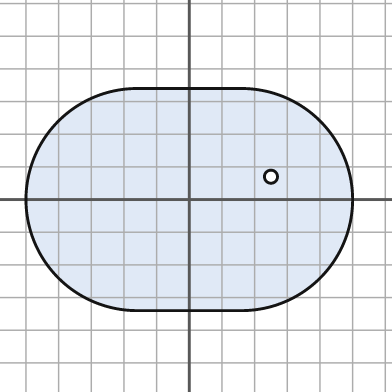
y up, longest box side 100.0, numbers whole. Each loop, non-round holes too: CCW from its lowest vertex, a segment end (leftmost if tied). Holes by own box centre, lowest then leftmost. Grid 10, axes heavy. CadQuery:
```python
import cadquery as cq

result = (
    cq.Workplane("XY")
    .moveTo(-16.0, -34.0)
    .lineTo(16.0, -34.0)
    .threePointArc((50.0, 0.0), (16.0, 34.0))
    .lineTo(-16.0, 34.0)
    .threePointArc((-50.0, 0.0), (-16.0, -34.0))
    .close()
    .moveTo(25.0, 7.0)
    .circle(2.0)
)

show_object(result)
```